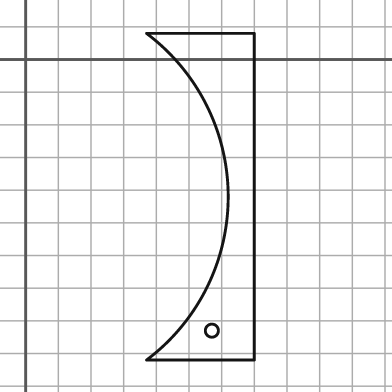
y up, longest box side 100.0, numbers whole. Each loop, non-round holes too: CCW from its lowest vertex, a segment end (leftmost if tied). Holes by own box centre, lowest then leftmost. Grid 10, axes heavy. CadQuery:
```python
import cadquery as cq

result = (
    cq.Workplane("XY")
    .moveTo(37.0, -92.0)
    .lineTo(70.0, -92.0)
    .lineTo(70.0, 8.0)
    .lineTo(37.0, 8.0)
    .threePointArc((62.0, -42.0), (37.0, -92.0))
    .close()
    .moveTo(57.0, -83.0)
    .circle(2.0)
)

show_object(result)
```